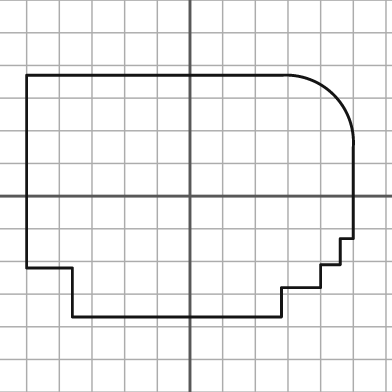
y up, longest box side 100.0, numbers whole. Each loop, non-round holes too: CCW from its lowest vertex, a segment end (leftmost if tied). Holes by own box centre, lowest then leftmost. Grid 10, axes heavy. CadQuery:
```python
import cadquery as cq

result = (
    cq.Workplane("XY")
    .moveTo(-36.0, -37.0)
    .lineTo(28.0, -37.0)
    .lineTo(28.0, -28.0)
    .lineTo(40.0, -28.0)
    .lineTo(40.0, -21.0)
    .lineTo(46.0, -21.0)
    .lineTo(46.0, -13.0)
    .lineTo(50.0, -13.0)
    .lineTo(50.0, 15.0)
    .threePointArc((44.0, 31.0), (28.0, 37.0))
    .lineTo(-50.0, 37.0)
    .lineTo(-50.0, -22.0)
    .lineTo(-36.0, -22.0)
    .close()
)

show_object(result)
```